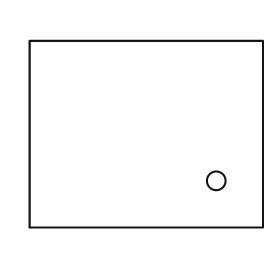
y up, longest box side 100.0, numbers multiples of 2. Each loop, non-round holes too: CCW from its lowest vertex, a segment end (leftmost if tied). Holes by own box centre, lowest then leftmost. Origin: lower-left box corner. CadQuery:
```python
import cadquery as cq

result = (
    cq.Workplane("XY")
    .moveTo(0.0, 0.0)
    .lineTo(100.0, 0.0)
    .lineTo(100.0, 80.0)
    .lineTo(0.0, 80.0)
    .close()
    .moveTo(80.0, 20.0)
    .circle(4.0)
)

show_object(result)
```